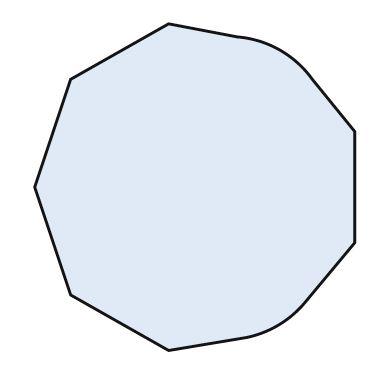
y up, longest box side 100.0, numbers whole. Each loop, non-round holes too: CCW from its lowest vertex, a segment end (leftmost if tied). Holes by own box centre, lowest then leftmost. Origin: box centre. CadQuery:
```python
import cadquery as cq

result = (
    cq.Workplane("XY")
    .moveTo(-8.0, -50.0)
    .lineTo(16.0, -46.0)
    .threePointArc((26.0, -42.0), (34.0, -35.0))
    .lineTo(49.0, -17.0)
    .lineTo(49.0, 17.0)
    .lineTo(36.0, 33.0)
    .threePointArc((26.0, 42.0), (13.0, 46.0))
    .lineTo(-8.0, 50.0)
    .lineTo(-38.0, 33.0)
    .lineTo(-49.0, 0.0)
    .lineTo(-38.0, -33.0)
    .close()
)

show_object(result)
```